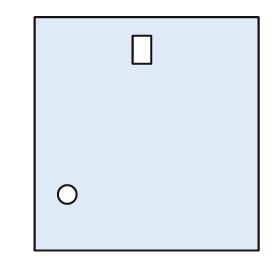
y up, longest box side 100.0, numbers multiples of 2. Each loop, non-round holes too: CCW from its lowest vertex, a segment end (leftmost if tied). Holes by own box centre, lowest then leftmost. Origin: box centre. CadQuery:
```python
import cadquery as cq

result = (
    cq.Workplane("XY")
    .moveTo(-48.0, -50.0)
    .lineTo(48.0, -50.0)
    .lineTo(48.0, 50.0)
    .lineTo(-48.0, 50.0)
    .close()
    .moveTo(-34.0, -26.0)
    .circle(4.0)
    .moveTo(-6.0, 30.0)
    .lineTo(2.0, 30.0)
    .lineTo(2.0, 42.0)
    .lineTo(-6.0, 42.0)
    .close()
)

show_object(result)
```